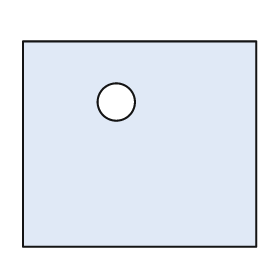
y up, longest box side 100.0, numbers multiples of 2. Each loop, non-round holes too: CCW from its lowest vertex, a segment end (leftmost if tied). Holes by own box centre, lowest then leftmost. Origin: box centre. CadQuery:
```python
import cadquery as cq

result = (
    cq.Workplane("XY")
    .moveTo(-50.0, -44.0)
    .lineTo(50.0, -44.0)
    .lineTo(50.0, 44.0)
    .lineTo(-50.0, 44.0)
    .close()
    .moveTo(-10.0, 18.0)
    .circle(8.0)
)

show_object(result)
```